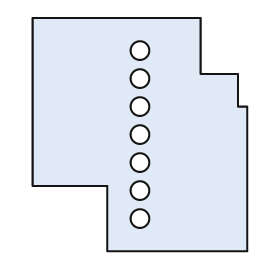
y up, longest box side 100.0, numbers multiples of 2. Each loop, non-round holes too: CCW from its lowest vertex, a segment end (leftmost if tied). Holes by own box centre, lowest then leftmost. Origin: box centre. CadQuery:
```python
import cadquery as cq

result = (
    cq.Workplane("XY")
    .moveTo(-14.0, -50.0)
    .lineTo(46.0, -50.0)
    .lineTo(46.0, 12.0)
    .lineTo(42.0, 12.0)
    .lineTo(42.0, 26.0)
    .lineTo(26.0, 26.0)
    .lineTo(26.0, 50.0)
    .lineTo(-46.0, 50.0)
    .lineTo(-46.0, -22.0)
    .lineTo(-14.0, -22.0)
    .close()
    .moveTo(0.0, -36.0)
    .circle(4.0)
    .moveTo(0.0, -24.0)
    .circle(4.0)
    .moveTo(0.0, -12.0)
    .circle(4.0)
    .moveTo(0.0, 0.0)
    .circle(4.0)
    .moveTo(0.0, 12.0)
    .circle(4.0)
    .moveTo(0.0, 24.0)
    .circle(4.0)
    .moveTo(0.0, 36.0)
    .circle(4.0)
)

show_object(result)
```